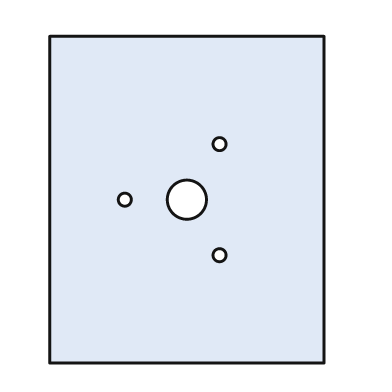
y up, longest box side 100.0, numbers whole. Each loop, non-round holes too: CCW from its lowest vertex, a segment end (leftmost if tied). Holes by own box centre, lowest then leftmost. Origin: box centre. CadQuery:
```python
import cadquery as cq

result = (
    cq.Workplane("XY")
    .moveTo(-42.0, -50.0)
    .lineTo(42.0, -50.0)
    .lineTo(42.0, 50.0)
    .lineTo(-42.0, 50.0)
    .close()
    .moveTo(10.0, -17.0)
    .circle(2.0)
    .moveTo(-19.0, 0.0)
    .circle(2.0)
    .moveTo(0.0, 0.0)
    .circle(6.0)
    .moveTo(10.0, 17.0)
    .circle(2.0)
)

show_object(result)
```